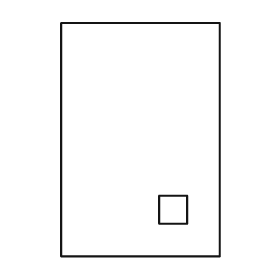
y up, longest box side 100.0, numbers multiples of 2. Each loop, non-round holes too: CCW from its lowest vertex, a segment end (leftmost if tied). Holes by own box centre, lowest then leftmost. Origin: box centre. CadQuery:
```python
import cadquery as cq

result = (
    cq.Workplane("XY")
    .moveTo(-34.0, -50.0)
    .lineTo(34.0, -50.0)
    .lineTo(34.0, 50.0)
    .lineTo(-34.0, 50.0)
    .close()
    .moveTo(8.0, -36.0)
    .lineTo(20.0, -36.0)
    .lineTo(20.0, -24.0)
    .lineTo(8.0, -24.0)
    .close()
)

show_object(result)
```